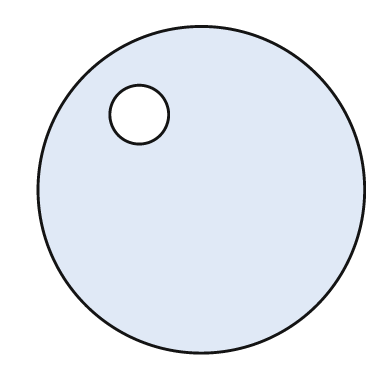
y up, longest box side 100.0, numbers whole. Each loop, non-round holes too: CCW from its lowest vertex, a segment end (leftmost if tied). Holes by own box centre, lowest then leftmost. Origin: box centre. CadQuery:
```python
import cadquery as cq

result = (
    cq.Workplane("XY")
    .moveTo(0.0, 0.0)
    .circle(50.0)
    .moveTo(-19.0, 23.0)
    .circle(9.0)
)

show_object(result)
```